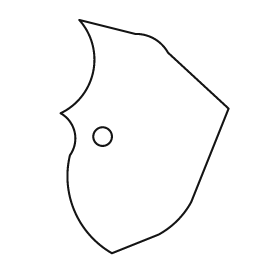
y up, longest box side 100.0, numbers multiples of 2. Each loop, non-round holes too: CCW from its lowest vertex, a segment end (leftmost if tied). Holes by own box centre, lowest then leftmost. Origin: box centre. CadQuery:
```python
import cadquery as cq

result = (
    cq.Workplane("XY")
    .moveTo(-14.0, -50.0)
    .lineTo(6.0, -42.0)
    .threePointArc((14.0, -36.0), (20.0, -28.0))
    .lineTo(36.0, 12.0)
    .lineTo(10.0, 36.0)
    .threePointArc((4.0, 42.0), (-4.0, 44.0))
    .lineTo(-28.0, 50.0)
    .threePointArc((-22.0, 28.0), (-36.0, 10.0))
    .threePointArc((-30.0, 2.0), (-32.0, -8.0))
    .threePointArc((-30.0, -32.0), (-14.0, -50.0))
    .close()
    .moveTo(-18.0, 0.0)
    .circle(4.0)
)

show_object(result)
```